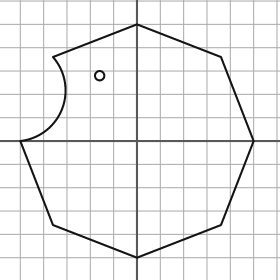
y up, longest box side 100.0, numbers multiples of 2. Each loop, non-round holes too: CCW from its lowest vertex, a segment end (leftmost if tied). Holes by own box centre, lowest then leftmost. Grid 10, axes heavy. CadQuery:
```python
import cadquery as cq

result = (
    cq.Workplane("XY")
    .moveTo(0.0, -50.0)
    .lineTo(36.0, -36.0)
    .lineTo(50.0, 0.0)
    .lineTo(36.0, 36.0)
    .lineTo(0.0, 50.0)
    .lineTo(-36.0, 36.0)
    .threePointArc((-32.0, 14.0), (-50.0, 0.0))
    .lineTo(-36.0, -36.0)
    .close()
    .moveTo(-16.0, 28.0)
    .circle(2.0)
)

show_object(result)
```